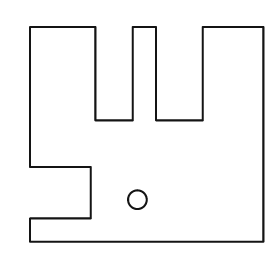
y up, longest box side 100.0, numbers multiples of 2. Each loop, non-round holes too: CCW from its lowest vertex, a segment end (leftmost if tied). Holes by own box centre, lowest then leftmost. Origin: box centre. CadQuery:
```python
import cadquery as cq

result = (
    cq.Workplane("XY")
    .moveTo(-50.0, -46.0)
    .lineTo(50.0, -46.0)
    .lineTo(50.0, 46.0)
    .lineTo(24.0, 46.0)
    .lineTo(24.0, 6.0)
    .lineTo(4.0, 6.0)
    .lineTo(4.0, 46.0)
    .lineTo(-6.0, 46.0)
    .lineTo(-6.0, 6.0)
    .lineTo(-22.0, 6.0)
    .lineTo(-22.0, 46.0)
    .lineTo(-50.0, 46.0)
    .lineTo(-50.0, -14.0)
    .lineTo(-24.0, -14.0)
    .lineTo(-24.0, -36.0)
    .lineTo(-50.0, -36.0)
    .close()
    .moveTo(-4.0, -28.0)
    .circle(4.0)
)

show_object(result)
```